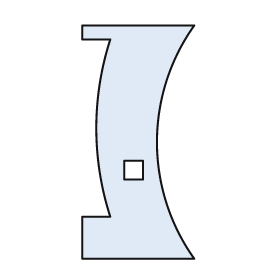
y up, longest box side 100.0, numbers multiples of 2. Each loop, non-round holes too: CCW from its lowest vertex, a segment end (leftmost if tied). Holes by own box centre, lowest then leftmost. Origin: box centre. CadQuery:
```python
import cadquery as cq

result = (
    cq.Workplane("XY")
    .moveTo(-24.0, -50.0)
    .lineTo(24.0, -50.0)
    .threePointArc((8.0, 0.0), (24.0, 50.0))
    .lineTo(-24.0, 50.0)
    .lineTo(-24.0, 44.0)
    .lineTo(-12.0, 44.0)
    .threePointArc((-18.0, 6.0), (-12.0, -32.0))
    .lineTo(-24.0, -32.0)
    .close()
    .moveTo(-6.0, -16.0)
    .lineTo(2.0, -16.0)
    .lineTo(2.0, -8.0)
    .lineTo(-6.0, -8.0)
    .close()
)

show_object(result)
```